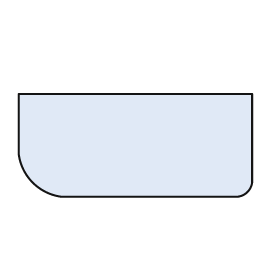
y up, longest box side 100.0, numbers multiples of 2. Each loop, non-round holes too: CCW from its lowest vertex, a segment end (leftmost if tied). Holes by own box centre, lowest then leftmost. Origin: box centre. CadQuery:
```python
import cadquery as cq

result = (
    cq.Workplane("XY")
    .moveTo(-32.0, -22.0)
    .lineTo(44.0, -22.0)
    .threePointArc((48.0, -20.0), (50.0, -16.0))
    .lineTo(50.0, 22.0)
    .lineTo(-50.0, 22.0)
    .lineTo(-50.0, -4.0)
    .threePointArc((-44.0, -16.0), (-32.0, -22.0))
    .close()
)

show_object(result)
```